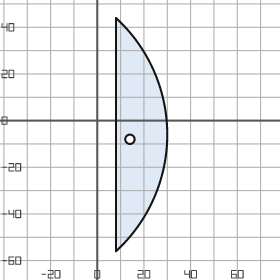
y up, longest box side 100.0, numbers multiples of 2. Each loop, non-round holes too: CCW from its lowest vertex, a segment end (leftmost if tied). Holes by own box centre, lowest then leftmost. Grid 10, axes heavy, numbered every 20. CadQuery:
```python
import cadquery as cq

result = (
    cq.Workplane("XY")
    .moveTo(8.0, -56.0)
    .threePointArc((30.0, -6.0), (8.0, 44.0))
    .close()
    .moveTo(14.0, -8.0)
    .circle(2.0)
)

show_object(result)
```